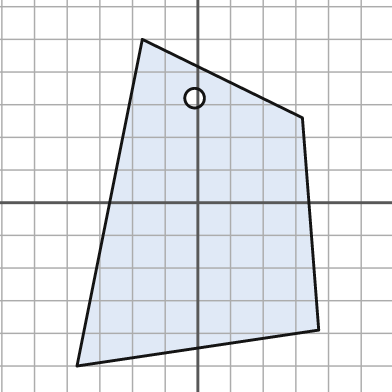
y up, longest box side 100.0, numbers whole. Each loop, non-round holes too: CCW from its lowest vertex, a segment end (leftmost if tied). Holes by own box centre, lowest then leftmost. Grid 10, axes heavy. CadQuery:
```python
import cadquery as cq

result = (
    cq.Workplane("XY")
    .moveTo(-37.0, -50.0)
    .lineTo(37.0, -39.0)
    .lineTo(32.0, 26.0)
    .lineTo(-17.0, 50.0)
    .close()
    .moveTo(-1.0, 32.0)
    .circle(3.0)
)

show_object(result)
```